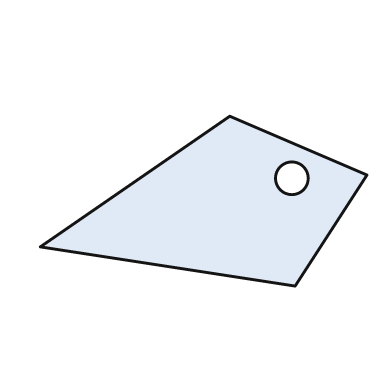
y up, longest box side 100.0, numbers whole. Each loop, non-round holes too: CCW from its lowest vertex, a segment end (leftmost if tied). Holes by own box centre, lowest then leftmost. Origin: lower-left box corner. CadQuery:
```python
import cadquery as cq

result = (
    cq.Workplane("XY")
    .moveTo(78.0, 0.0)
    .lineTo(100.0, 34.0)
    .lineTo(58.0, 52.0)
    .lineTo(0.0, 12.0)
    .close()
    .moveTo(77.0, 33.0)
    .circle(5.0)
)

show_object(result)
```